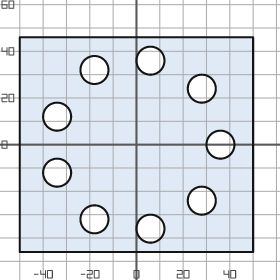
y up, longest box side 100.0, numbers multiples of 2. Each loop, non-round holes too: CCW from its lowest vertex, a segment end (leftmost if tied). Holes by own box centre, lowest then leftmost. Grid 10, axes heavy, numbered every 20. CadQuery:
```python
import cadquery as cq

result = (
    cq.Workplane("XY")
    .moveTo(-50.0, -46.0)
    .lineTo(50.0, -46.0)
    .lineTo(50.0, 46.0)
    .lineTo(-50.0, 46.0)
    .close()
    .moveTo(6.0, -36.0)
    .circle(6.0)
    .moveTo(-18.0, -32.0)
    .circle(6.0)
    .moveTo(28.0, -24.0)
    .circle(6.0)
    .moveTo(-34.0, -12.0)
    .circle(6.0)
    .moveTo(36.0, 0.0)
    .circle(6.0)
    .moveTo(-34.0, 12.0)
    .circle(6.0)
    .moveTo(28.0, 24.0)
    .circle(6.0)
    .moveTo(-18.0, 32.0)
    .circle(6.0)
    .moveTo(6.0, 36.0)
    .circle(6.0)
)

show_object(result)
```